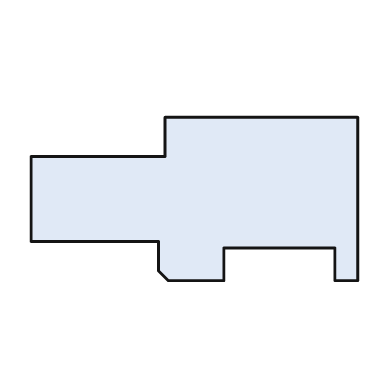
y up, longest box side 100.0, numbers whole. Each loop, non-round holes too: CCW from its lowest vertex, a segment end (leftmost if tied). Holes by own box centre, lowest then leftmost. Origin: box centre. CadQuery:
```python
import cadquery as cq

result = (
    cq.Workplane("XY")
    .moveTo(-8.0, -25.0)
    .lineTo(9.0, -25.0)
    .lineTo(9.0, -15.0)
    .lineTo(43.0, -15.0)
    .lineTo(43.0, -25.0)
    .lineTo(50.0, -25.0)
    .lineTo(50.0, 25.0)
    .lineTo(-9.0, 25.0)
    .lineTo(-9.0, 13.0)
    .lineTo(-50.0, 13.0)
    .lineTo(-50.0, -13.0)
    .lineTo(-11.0, -13.0)
    .lineTo(-11.0, -22.0)
    .close()
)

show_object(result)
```